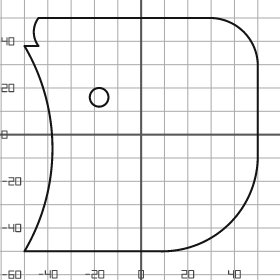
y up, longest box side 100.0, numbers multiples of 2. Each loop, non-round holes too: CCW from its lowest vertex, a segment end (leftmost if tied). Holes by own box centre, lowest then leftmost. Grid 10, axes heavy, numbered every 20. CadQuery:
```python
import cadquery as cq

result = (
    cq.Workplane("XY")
    .moveTo(-50.0, -50.0)
    .lineTo(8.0, -50.0)
    .threePointArc((38.0, -38.0), (50.0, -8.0))
    .lineTo(50.0, 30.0)
    .threePointArc((44.0, 44.0), (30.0, 50.0))
    .lineTo(-44.0, 50.0)
    .threePointArc((-46.0, 44.0), (-44.0, 38.0))
    .lineTo(-50.0, 38.0)
    .threePointArc((-38.0, -6.0), (-50.0, -50.0))
    .close()
    .moveTo(-18.0, 16.0)
    .circle(4.0)
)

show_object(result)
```